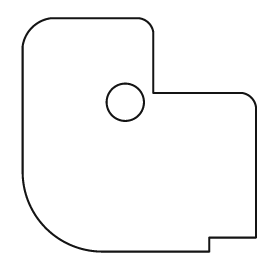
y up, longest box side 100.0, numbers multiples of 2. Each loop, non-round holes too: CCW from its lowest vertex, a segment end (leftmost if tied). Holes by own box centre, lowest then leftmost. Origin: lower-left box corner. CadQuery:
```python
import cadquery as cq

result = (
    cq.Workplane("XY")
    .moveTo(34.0, 0.0)
    .lineTo(80.0, 0.0)
    .lineTo(80.0, 6.0)
    .lineTo(100.0, 6.0)
    .lineTo(100.0, 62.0)
    .threePointArc((98.0, 66.0), (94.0, 68.0))
    .lineTo(56.0, 68.0)
    .lineTo(56.0, 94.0)
    .threePointArc((54.0, 98.0), (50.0, 100.0))
    .lineTo(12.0, 100.0)
    .threePointArc((4.0, 96.0), (0.0, 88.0))
    .lineTo(0.0, 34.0)
    .threePointArc((10.0, 10.0), (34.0, 0.0))
    .close()
    .moveTo(44.0, 64.0)
    .circle(8.0)
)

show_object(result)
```